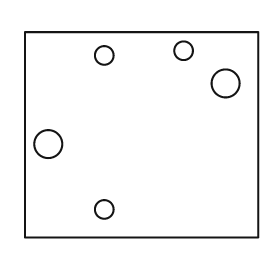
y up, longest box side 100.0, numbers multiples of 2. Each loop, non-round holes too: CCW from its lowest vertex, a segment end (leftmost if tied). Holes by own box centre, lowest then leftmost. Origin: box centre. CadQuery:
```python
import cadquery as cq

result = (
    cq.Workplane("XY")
    .moveTo(-50.0, -44.0)
    .lineTo(50.0, -44.0)
    .lineTo(50.0, 44.0)
    .lineTo(-50.0, 44.0)
    .close()
    .moveTo(-16.0, -32.0)
    .circle(4.0)
    .moveTo(-40.0, -4.0)
    .circle(6.0)
    .moveTo(36.0, 22.0)
    .circle(6.0)
    .moveTo(-16.0, 34.0)
    .circle(4.0)
    .moveTo(18.0, 36.0)
    .circle(4.0)
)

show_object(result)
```